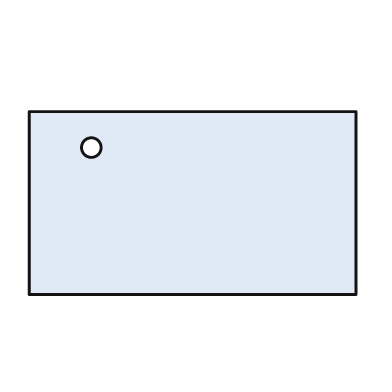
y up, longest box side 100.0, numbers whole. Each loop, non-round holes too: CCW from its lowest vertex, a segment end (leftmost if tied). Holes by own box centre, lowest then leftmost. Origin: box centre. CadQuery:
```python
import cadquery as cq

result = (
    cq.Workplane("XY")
    .moveTo(-50.0, -28.0)
    .lineTo(50.0, -28.0)
    .lineTo(50.0, 28.0)
    .lineTo(-50.0, 28.0)
    .close()
    .moveTo(-31.0, 17.0)
    .circle(3.0)
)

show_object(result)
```